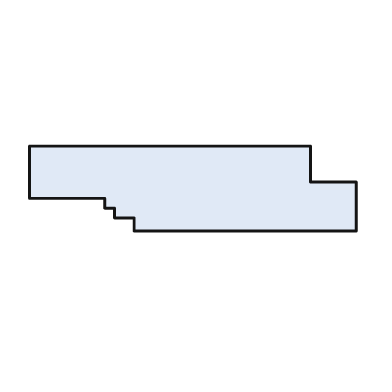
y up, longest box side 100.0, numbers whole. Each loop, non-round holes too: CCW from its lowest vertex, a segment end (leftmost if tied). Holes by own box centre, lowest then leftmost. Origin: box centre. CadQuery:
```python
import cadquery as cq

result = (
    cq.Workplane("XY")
    .moveTo(-18.0, -13.0)
    .lineTo(50.0, -13.0)
    .lineTo(50.0, 2.0)
    .lineTo(36.0, 2.0)
    .lineTo(36.0, 13.0)
    .lineTo(-50.0, 13.0)
    .lineTo(-50.0, -3.0)
    .lineTo(-27.0, -3.0)
    .lineTo(-27.0, -6.0)
    .lineTo(-24.0, -6.0)
    .lineTo(-24.0, -9.0)
    .lineTo(-18.0, -9.0)
    .close()
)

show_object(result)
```